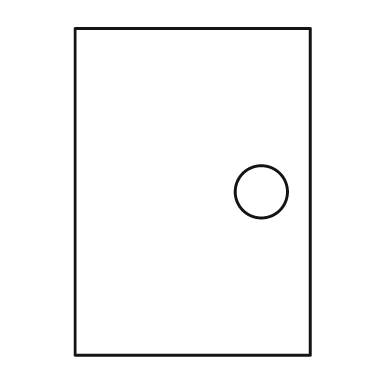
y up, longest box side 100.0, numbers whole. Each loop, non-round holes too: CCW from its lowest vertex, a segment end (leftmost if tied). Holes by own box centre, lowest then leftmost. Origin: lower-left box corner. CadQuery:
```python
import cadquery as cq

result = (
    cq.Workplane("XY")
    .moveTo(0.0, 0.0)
    .lineTo(72.0, 0.0)
    .lineTo(72.0, 100.0)
    .lineTo(0.0, 100.0)
    .close()
    .moveTo(57.0, 50.0)
    .circle(8.0)
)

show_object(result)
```